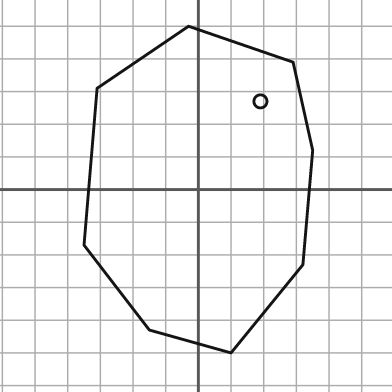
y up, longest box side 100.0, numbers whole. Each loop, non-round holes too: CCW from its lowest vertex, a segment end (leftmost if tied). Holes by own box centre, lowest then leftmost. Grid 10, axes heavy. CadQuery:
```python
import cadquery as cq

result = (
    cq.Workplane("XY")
    .moveTo(10.0, -50.0)
    .lineTo(32.0, -23.0)
    .lineTo(35.0, 12.0)
    .lineTo(29.0, 39.0)
    .lineTo(-3.0, 50.0)
    .lineTo(-31.0, 31.0)
    .lineTo(-35.0, -17.0)
    .lineTo(-15.0, -43.0)
    .close()
    .moveTo(19.0, 27.0)
    .circle(2.0)
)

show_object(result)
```